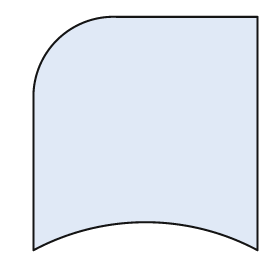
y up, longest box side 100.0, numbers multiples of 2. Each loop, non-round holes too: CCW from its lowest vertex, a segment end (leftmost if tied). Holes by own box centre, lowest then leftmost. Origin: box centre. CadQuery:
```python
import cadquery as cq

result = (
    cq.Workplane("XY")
    .moveTo(-48.0, -50.0)
    .threePointArc((0.0, -38.0), (48.0, -50.0))
    .lineTo(48.0, 50.0)
    .lineTo(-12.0, 50.0)
    .threePointArc((-38.0, 40.0), (-48.0, 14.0))
    .close()
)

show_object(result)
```